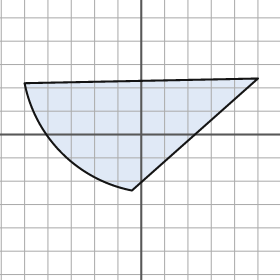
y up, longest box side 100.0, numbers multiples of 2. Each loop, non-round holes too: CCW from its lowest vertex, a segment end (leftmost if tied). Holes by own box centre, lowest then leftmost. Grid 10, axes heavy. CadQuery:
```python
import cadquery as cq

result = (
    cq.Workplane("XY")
    .moveTo(-4.0, -24.0)
    .lineTo(50.0, 24.0)
    .lineTo(-50.0, 22.0)
    .threePointArc((-34.0, -8.0), (-4.0, -24.0))
    .close()
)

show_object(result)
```